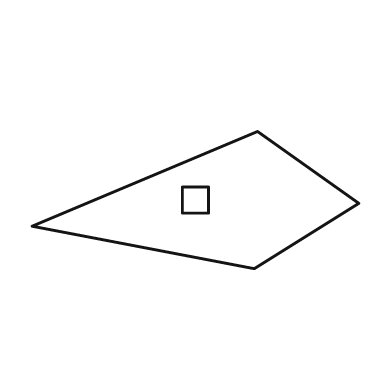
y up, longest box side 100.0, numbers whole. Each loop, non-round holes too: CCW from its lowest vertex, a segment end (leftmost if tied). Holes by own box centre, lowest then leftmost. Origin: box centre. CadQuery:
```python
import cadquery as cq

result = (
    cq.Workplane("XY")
    .moveTo(18.0, -21.0)
    .lineTo(50.0, -1.0)
    .lineTo(19.0, 21.0)
    .lineTo(-50.0, -8.0)
    .close()
    .moveTo(-4.0, -4.0)
    .lineTo(4.0, -4.0)
    .lineTo(4.0, 4.0)
    .lineTo(-4.0, 4.0)
    .close()
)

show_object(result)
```